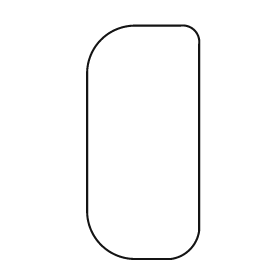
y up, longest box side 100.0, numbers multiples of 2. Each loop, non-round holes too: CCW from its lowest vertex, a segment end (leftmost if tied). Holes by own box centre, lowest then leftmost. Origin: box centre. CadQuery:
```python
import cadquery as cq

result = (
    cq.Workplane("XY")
    .moveTo(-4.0, -50.0)
    .lineTo(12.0, -50.0)
    .threePointArc((20.0, -46.0), (24.0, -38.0))
    .lineTo(24.0, 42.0)
    .threePointArc((22.0, 48.0), (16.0, 50.0))
    .lineTo(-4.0, 50.0)
    .threePointArc((-18.0, 44.0), (-24.0, 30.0))
    .lineTo(-24.0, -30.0)
    .threePointArc((-18.0, -44.0), (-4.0, -50.0))
    .close()
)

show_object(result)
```